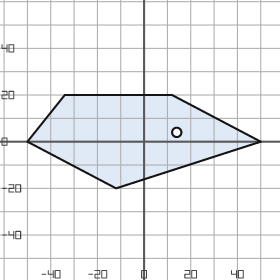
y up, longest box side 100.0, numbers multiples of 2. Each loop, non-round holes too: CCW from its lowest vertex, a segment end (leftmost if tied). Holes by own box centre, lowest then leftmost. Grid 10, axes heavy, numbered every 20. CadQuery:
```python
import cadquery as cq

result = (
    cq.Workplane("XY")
    .moveTo(-12.0, -20.0)
    .lineTo(50.0, 0.0)
    .lineTo(12.0, 20.0)
    .lineTo(-34.0, 20.0)
    .lineTo(-50.0, 0.0)
    .close()
    .moveTo(14.0, 4.0)
    .circle(2.0)
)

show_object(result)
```